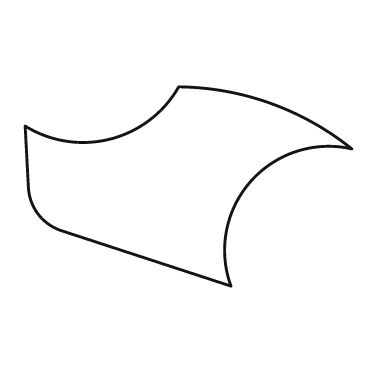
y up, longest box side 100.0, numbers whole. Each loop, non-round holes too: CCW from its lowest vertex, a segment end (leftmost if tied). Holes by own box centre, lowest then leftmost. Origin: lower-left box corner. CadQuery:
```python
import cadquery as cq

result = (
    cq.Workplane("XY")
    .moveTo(63.0, 0.0)
    .threePointArc((69.0, 32.0), (100.0, 42.0))
    .threePointArc((75.0, 56.0), (47.0, 61.0))
    .threePointArc((26.0, 45.0), (0.0, 49.0))
    .lineTo(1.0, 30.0)
    .threePointArc((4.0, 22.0), (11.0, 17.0))
    .close()
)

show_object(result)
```